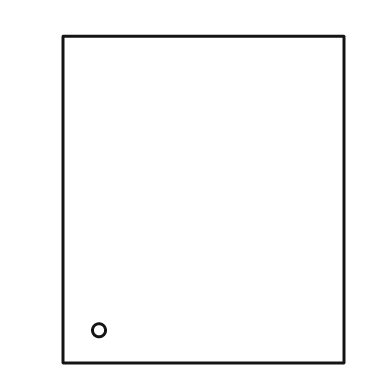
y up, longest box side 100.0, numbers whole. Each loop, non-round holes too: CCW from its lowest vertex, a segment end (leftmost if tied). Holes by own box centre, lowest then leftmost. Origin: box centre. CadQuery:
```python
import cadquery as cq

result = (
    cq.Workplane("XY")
    .moveTo(-43.0, -50.0)
    .lineTo(43.0, -50.0)
    .lineTo(43.0, 50.0)
    .lineTo(-43.0, 50.0)
    .close()
    .moveTo(-32.0, -40.0)
    .circle(2.0)
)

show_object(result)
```